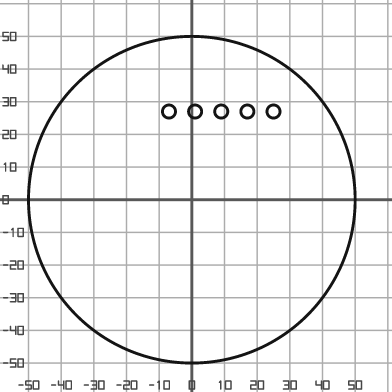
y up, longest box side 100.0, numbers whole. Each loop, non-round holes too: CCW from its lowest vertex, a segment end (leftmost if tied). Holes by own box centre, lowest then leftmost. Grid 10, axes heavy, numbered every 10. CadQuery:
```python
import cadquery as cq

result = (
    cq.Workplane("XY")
    .moveTo(0.0, 0.0)
    .circle(50.0)
    .moveTo(-7.0, 27.0)
    .circle(2.0)
    .moveTo(1.0, 27.0)
    .circle(2.0)
    .moveTo(9.0, 27.0)
    .circle(2.0)
    .moveTo(17.0, 27.0)
    .circle(2.0)
    .moveTo(25.0, 27.0)
    .circle(2.0)
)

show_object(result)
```